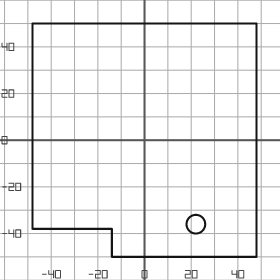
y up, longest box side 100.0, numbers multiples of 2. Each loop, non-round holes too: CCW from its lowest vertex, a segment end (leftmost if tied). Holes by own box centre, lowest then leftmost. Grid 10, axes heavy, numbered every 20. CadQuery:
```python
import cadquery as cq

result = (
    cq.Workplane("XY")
    .moveTo(-14.0, -50.0)
    .lineTo(48.0, -50.0)
    .lineTo(48.0, 50.0)
    .lineTo(-48.0, 50.0)
    .lineTo(-48.0, -38.0)
    .lineTo(-14.0, -38.0)
    .close()
    .moveTo(22.0, -36.0)
    .circle(4.0)
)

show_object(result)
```